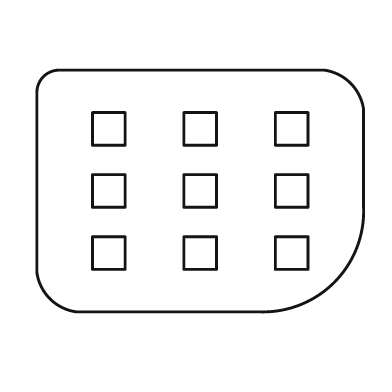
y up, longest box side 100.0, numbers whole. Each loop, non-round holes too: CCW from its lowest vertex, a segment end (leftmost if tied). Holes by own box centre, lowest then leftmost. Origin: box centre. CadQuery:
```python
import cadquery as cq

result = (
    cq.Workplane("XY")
    .moveTo(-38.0, -37.0)
    .lineTo(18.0, -37.0)
    .threePointArc((41.0, -28.0), (50.0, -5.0))
    .lineTo(50.0, 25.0)
    .threePointArc((46.0, 33.0), (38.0, 37.0))
    .lineTo(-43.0, 37.0)
    .threePointArc((-48.0, 35.0), (-50.0, 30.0))
    .lineTo(-50.0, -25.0)
    .threePointArc((-46.0, -33.0), (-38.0, -37.0))
    .close()
    .moveTo(-33.0, -24.0)
    .lineTo(-23.0, -24.0)
    .lineTo(-23.0, -14.0)
    .lineTo(-33.0, -14.0)
    .close()
    .moveTo(-5.0, -24.0)
    .lineTo(5.0, -24.0)
    .lineTo(5.0, -14.0)
    .lineTo(-5.0, -14.0)
    .close()
    .moveTo(23.0, -24.0)
    .lineTo(33.0, -24.0)
    .lineTo(33.0, -14.0)
    .lineTo(23.0, -14.0)
    .close()
    .moveTo(-33.0, -5.0)
    .lineTo(-23.0, -5.0)
    .lineTo(-23.0, 5.0)
    .lineTo(-33.0, 5.0)
    .close()
    .moveTo(-5.0, -5.0)
    .lineTo(5.0, -5.0)
    .lineTo(5.0, 5.0)
    .lineTo(-5.0, 5.0)
    .close()
    .moveTo(23.0, -5.0)
    .lineTo(33.0, -5.0)
    .lineTo(33.0, 5.0)
    .lineTo(23.0, 5.0)
    .close()
    .moveTo(-33.0, 14.0)
    .lineTo(-23.0, 14.0)
    .lineTo(-23.0, 24.0)
    .lineTo(-33.0, 24.0)
    .close()
    .moveTo(-5.0, 14.0)
    .lineTo(5.0, 14.0)
    .lineTo(5.0, 24.0)
    .lineTo(-5.0, 24.0)
    .close()
    .moveTo(23.0, 14.0)
    .lineTo(33.0, 14.0)
    .lineTo(33.0, 24.0)
    .lineTo(23.0, 24.0)
    .close()
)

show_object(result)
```